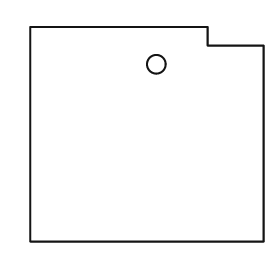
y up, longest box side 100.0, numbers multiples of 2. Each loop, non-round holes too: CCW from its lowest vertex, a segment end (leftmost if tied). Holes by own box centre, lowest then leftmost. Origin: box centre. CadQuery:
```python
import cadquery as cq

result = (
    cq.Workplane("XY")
    .moveTo(-50.0, -46.0)
    .lineTo(50.0, -46.0)
    .lineTo(50.0, 38.0)
    .lineTo(26.0, 38.0)
    .lineTo(26.0, 46.0)
    .lineTo(-50.0, 46.0)
    .close()
    .moveTo(4.0, 30.0)
    .circle(4.0)
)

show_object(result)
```